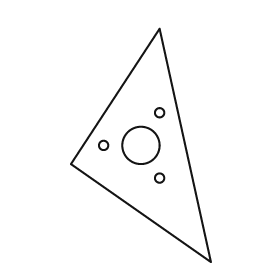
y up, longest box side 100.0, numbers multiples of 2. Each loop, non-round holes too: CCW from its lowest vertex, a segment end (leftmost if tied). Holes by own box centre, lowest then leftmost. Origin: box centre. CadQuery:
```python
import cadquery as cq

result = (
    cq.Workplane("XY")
    .moveTo(30.0, -50.0)
    .lineTo(8.0, 50.0)
    .lineTo(-30.0, -8.0)
    .close()
    .moveTo(8.0, -14.0)
    .circle(2.0)
    .moveTo(-16.0, 0.0)
    .circle(2.0)
    .moveTo(0.0, 0.0)
    .circle(8.0)
    .moveTo(8.0, 14.0)
    .circle(2.0)
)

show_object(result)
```